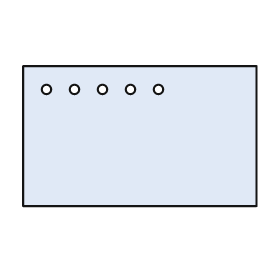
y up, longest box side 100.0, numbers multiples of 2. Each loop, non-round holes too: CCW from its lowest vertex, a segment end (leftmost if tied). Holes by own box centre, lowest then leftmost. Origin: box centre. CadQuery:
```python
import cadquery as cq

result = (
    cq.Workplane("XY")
    .moveTo(-50.0, -30.0)
    .lineTo(50.0, -30.0)
    .lineTo(50.0, 30.0)
    .lineTo(-50.0, 30.0)
    .close()
    .moveTo(-40.0, 20.0)
    .circle(2.0)
    .moveTo(-28.0, 20.0)
    .circle(2.0)
    .moveTo(-16.0, 20.0)
    .circle(2.0)
    .moveTo(-4.0, 20.0)
    .circle(2.0)
    .moveTo(8.0, 20.0)
    .circle(2.0)
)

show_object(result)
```